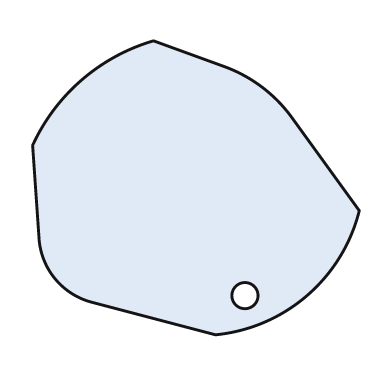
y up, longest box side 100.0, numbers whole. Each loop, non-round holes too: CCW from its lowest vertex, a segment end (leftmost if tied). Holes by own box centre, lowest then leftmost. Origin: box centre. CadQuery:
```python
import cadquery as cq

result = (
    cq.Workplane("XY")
    .moveTo(6.0, -45.0)
    .threePointArc((34.0, -33.0), (50.0, -7.0))
    .lineTo(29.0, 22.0)
    .threePointArc((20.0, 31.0), (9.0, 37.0))
    .lineTo(-13.0, 45.0)
    .threePointArc((-35.0, 33.0), (-50.0, 13.0))
    .lineTo(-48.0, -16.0)
    .threePointArc((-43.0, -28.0), (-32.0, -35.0))
    .close()
    .moveTo(15.0, -33.0)
    .circle(4.0)
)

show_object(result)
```